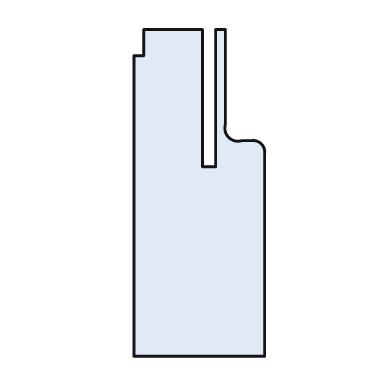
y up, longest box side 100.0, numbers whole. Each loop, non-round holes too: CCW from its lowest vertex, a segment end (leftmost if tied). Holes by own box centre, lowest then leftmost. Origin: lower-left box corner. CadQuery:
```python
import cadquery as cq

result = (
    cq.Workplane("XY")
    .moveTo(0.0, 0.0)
    .lineTo(40.0, 0.0)
    .lineTo(40.0, 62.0)
    .threePointArc((39.0, 65.0), (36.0, 66.0))
    .lineTo(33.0, 66.0)
    .threePointArc((29.0, 67.0), (28.0, 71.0))
    .lineTo(28.0, 100.0)
    .lineTo(25.0, 100.0)
    .lineTo(25.0, 58.0)
    .lineTo(21.0, 58.0)
    .lineTo(21.0, 100.0)
    .lineTo(3.0, 100.0)
    .lineTo(3.0, 92.0)
    .lineTo(0.0, 92.0)
    .close()
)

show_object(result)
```